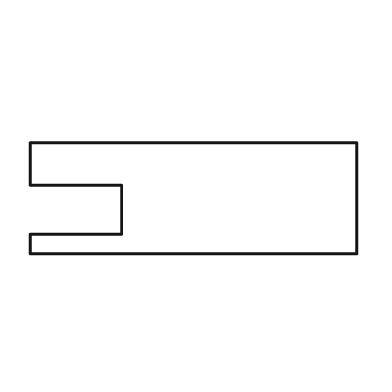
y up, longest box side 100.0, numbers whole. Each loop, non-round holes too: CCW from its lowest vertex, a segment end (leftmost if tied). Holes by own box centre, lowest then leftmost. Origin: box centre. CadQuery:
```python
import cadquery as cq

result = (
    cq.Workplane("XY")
    .moveTo(-50.0, -17.0)
    .lineTo(50.0, -17.0)
    .lineTo(50.0, 17.0)
    .lineTo(-50.0, 17.0)
    .lineTo(-50.0, 4.0)
    .lineTo(-22.0, 4.0)
    .lineTo(-22.0, -11.0)
    .lineTo(-50.0, -11.0)
    .close()
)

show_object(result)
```